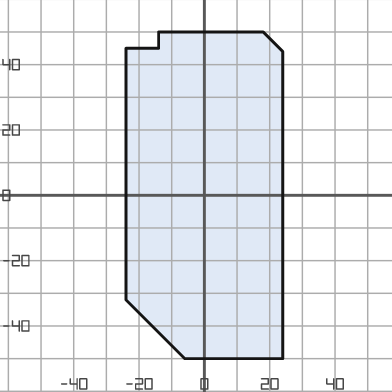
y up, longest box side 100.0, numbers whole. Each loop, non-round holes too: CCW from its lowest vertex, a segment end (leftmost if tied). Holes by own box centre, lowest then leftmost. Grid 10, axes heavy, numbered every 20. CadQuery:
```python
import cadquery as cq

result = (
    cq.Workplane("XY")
    .moveTo(-6.0, -50.0)
    .lineTo(24.0, -50.0)
    .lineTo(24.0, 44.0)
    .lineTo(18.0, 50.0)
    .lineTo(-14.0, 50.0)
    .lineTo(-14.0, 45.0)
    .lineTo(-24.0, 45.0)
    .lineTo(-24.0, -32.0)
    .close()
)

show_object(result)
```